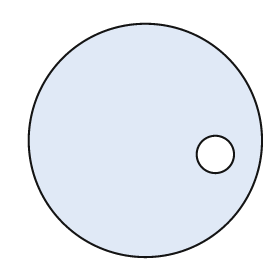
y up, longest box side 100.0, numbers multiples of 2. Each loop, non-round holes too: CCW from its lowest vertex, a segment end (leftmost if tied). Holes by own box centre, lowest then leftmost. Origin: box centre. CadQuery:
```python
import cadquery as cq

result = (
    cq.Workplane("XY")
    .moveTo(0.0, 0.0)
    .circle(50.0)
    .moveTo(30.0, -6.0)
    .circle(8.0)
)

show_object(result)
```